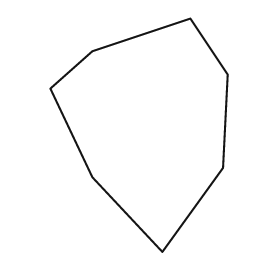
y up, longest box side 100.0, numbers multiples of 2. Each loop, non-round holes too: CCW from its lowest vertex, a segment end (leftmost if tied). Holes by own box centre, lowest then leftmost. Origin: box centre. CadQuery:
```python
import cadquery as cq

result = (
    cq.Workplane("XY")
    .moveTo(10.0, -50.0)
    .lineTo(36.0, -14.0)
    .lineTo(38.0, 26.0)
    .lineTo(22.0, 50.0)
    .lineTo(-20.0, 36.0)
    .lineTo(-38.0, 20.0)
    .lineTo(-20.0, -18.0)
    .close()
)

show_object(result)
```